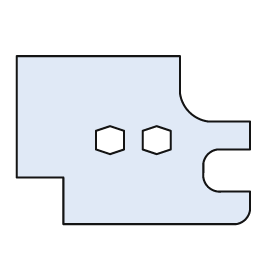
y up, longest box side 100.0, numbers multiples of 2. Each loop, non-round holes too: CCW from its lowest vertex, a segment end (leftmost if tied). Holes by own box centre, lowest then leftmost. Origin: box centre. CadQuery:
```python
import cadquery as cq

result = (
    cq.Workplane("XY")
    .moveTo(-30.0, -36.0)
    .lineTo(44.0, -36.0)
    .threePointArc((48.0, -34.0), (50.0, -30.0))
    .lineTo(50.0, -22.0)
    .lineTo(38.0, -22.0)
    .threePointArc((32.0, -20.0), (30.0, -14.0))
    .lineTo(30.0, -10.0)
    .threePointArc((32.0, -6.0), (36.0, -4.0))
    .lineTo(50.0, -4.0)
    .lineTo(50.0, 8.0)
    .lineTo(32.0, 8.0)
    .threePointArc((24.0, 12.0), (20.0, 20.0))
    .lineTo(20.0, 36.0)
    .lineTo(-50.0, 36.0)
    .lineTo(-50.0, -16.0)
    .lineTo(-30.0, -16.0)
    .close()
    .moveTo(-10.0, -6.0)
    .lineTo(-4.0, -4.0)
    .lineTo(-4.0, 4.0)
    .lineTo(-10.0, 6.0)
    .lineTo(-16.0, 4.0)
    .lineTo(-16.0, -4.0)
    .close()
    .moveTo(10.0, -6.0)
    .lineTo(16.0, -4.0)
    .lineTo(16.0, 4.0)
    .lineTo(10.0, 6.0)
    .lineTo(4.0, 4.0)
    .lineTo(4.0, -4.0)
    .close()
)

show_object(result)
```